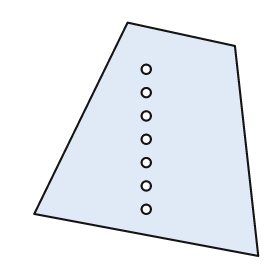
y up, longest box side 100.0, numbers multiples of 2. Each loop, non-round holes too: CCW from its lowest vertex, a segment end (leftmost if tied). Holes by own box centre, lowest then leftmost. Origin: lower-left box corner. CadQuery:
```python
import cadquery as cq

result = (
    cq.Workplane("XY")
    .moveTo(96.0, 0.0)
    .lineTo(86.0, 90.0)
    .lineTo(40.0, 100.0)
    .lineTo(0.0, 18.0)
    .close()
    .moveTo(48.0, 20.0)
    .circle(2.0)
    .moveTo(48.0, 30.0)
    .circle(2.0)
    .moveTo(48.0, 40.0)
    .circle(2.0)
    .moveTo(48.0, 50.0)
    .circle(2.0)
    .moveTo(48.0, 60.0)
    .circle(2.0)
    .moveTo(48.0, 70.0)
    .circle(2.0)
    .moveTo(48.0, 80.0)
    .circle(2.0)
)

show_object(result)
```